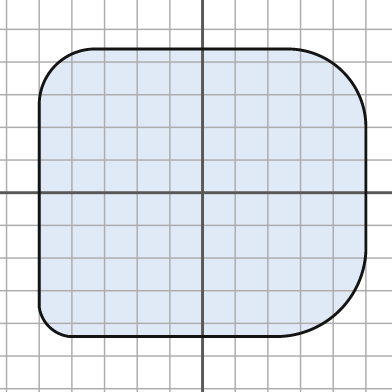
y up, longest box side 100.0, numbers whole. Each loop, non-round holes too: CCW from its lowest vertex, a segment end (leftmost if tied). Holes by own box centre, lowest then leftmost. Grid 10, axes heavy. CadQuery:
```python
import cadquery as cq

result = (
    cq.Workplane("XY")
    .moveTo(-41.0, -44.0)
    .lineTo(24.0, -44.0)
    .threePointArc((42.0, -36.0), (50.0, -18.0))
    .lineTo(50.0, 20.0)
    .threePointArc((43.0, 37.0), (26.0, 44.0))
    .lineTo(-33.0, 44.0)
    .threePointArc((-45.0, 39.0), (-50.0, 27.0))
    .lineTo(-50.0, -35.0)
    .threePointArc((-47.0, -41.0), (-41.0, -44.0))
    .close()
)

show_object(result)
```